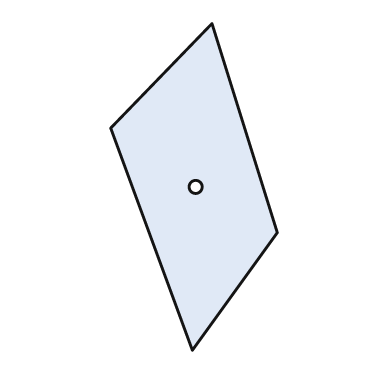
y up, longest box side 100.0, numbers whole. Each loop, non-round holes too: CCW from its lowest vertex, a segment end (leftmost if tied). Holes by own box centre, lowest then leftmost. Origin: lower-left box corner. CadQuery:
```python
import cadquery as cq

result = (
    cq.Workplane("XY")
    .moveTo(25.0, 0.0)
    .lineTo(51.0, 36.0)
    .lineTo(31.0, 100.0)
    .lineTo(0.0, 68.0)
    .close()
    .moveTo(26.0, 50.0)
    .circle(2.0)
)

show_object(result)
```